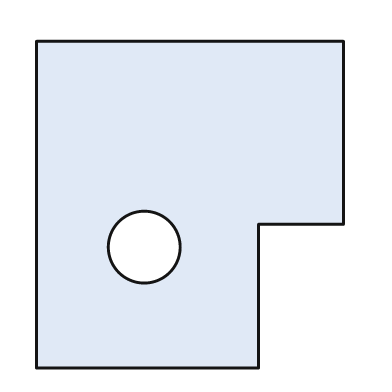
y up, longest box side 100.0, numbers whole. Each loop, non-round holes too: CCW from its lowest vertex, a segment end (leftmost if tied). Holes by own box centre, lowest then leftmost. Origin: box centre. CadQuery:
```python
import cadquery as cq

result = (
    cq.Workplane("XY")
    .moveTo(-47.0, -50.0)
    .lineTo(21.0, -50.0)
    .lineTo(21.0, -6.0)
    .lineTo(47.0, -6.0)
    .lineTo(47.0, 50.0)
    .lineTo(-47.0, 50.0)
    .close()
    .moveTo(-14.0, -13.0)
    .circle(11.0)
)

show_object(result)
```